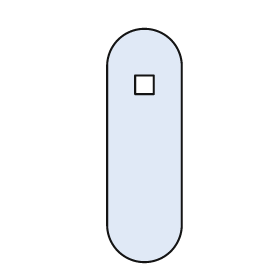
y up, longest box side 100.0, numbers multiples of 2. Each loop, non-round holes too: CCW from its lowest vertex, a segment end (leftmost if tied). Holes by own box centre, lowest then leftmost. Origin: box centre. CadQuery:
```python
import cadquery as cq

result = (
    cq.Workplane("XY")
    .moveTo(-16.0, -34.0)
    .threePointArc((0.0, -50.0), (16.0, -34.0))
    .lineTo(16.0, 34.0)
    .threePointArc((0.0, 50.0), (-16.0, 34.0))
    .close()
    .moveTo(-4.0, 22.0)
    .lineTo(4.0, 22.0)
    .lineTo(4.0, 30.0)
    .lineTo(-4.0, 30.0)
    .close()
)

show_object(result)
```